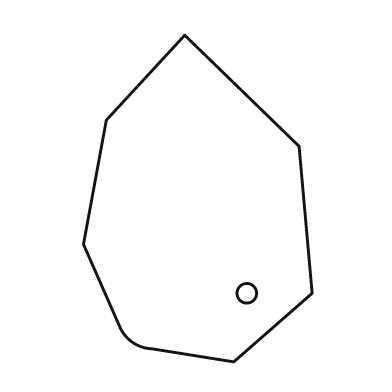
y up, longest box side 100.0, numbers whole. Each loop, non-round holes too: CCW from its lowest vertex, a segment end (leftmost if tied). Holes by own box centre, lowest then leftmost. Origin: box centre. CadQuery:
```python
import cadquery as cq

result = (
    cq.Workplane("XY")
    .moveTo(11.0, -50.0)
    .lineTo(35.0, -29.0)
    .lineTo(31.0, 16.0)
    .lineTo(-4.0, 50.0)
    .lineTo(-28.0, 24.0)
    .lineTo(-35.0, -14.0)
    .lineTo(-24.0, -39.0)
    .threePointArc((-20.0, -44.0), (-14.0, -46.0))
    .close()
    .moveTo(15.0, -29.0)
    .circle(3.0)
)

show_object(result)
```